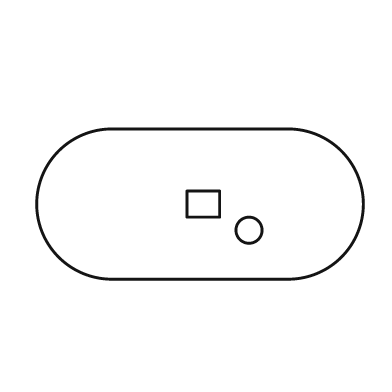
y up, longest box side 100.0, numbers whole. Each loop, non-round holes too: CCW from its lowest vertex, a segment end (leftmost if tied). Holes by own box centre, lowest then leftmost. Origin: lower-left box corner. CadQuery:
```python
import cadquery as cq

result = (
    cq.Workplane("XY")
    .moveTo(23.0, 0.0)
    .lineTo(77.0, 0.0)
    .threePointArc((100.0, 23.0), (77.0, 46.0))
    .lineTo(23.0, 46.0)
    .threePointArc((0.0, 23.0), (23.0, 0.0))
    .close()
    .moveTo(65.0, 15.0)
    .circle(4.0)
    .moveTo(46.0, 19.0)
    .lineTo(56.0, 19.0)
    .lineTo(56.0, 27.0)
    .lineTo(46.0, 27.0)
    .close()
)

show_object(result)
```